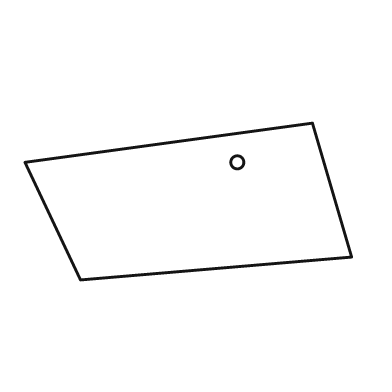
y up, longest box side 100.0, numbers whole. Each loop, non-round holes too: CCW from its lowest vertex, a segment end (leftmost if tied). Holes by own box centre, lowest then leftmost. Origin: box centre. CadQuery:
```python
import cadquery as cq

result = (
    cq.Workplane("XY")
    .moveTo(-33.0, -24.0)
    .lineTo(50.0, -17.0)
    .lineTo(38.0, 24.0)
    .lineTo(-50.0, 12.0)
    .close()
    .moveTo(15.0, 12.0)
    .circle(2.0)
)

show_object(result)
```